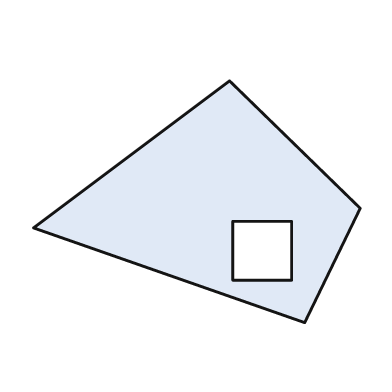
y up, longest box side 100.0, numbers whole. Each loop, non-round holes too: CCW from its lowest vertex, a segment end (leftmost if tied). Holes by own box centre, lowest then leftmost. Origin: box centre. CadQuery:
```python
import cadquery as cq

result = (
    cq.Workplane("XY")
    .moveTo(33.0, -37.0)
    .lineTo(50.0, -2.0)
    .lineTo(10.0, 37.0)
    .lineTo(-50.0, -8.0)
    .close()
    .moveTo(11.0, -24.0)
    .lineTo(29.0, -24.0)
    .lineTo(29.0, -6.0)
    .lineTo(11.0, -6.0)
    .close()
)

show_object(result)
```